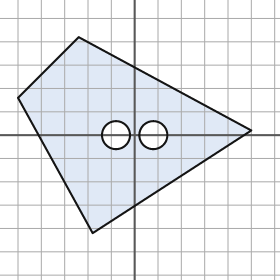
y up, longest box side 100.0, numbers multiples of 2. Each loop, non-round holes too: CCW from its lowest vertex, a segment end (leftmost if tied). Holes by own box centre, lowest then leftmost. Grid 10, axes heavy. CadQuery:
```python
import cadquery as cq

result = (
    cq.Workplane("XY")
    .moveTo(-18.0, -42.0)
    .lineTo(50.0, 2.0)
    .lineTo(-24.0, 42.0)
    .lineTo(-50.0, 16.0)
    .close()
    .moveTo(-8.0, 0.0)
    .circle(6.0)
    .moveTo(8.0, 0.0)
    .circle(6.0)
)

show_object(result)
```